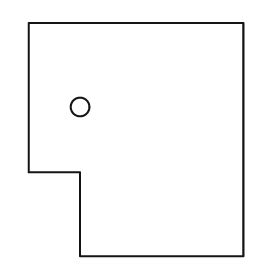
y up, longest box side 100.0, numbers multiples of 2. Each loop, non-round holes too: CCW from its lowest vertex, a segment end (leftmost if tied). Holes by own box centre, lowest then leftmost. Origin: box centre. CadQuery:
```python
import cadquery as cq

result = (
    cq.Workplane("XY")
    .moveTo(-24.0, -50.0)
    .lineTo(46.0, -50.0)
    .lineTo(46.0, 50.0)
    .lineTo(-46.0, 50.0)
    .lineTo(-46.0, -14.0)
    .lineTo(-24.0, -14.0)
    .close()
    .moveTo(-24.0, 14.0)
    .circle(4.0)
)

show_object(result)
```